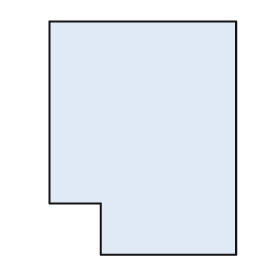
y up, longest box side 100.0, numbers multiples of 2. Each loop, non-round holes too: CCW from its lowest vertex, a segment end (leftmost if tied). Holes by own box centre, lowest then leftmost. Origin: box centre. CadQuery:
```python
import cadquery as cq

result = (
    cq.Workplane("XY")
    .moveTo(-18.0, -50.0)
    .lineTo(40.0, -50.0)
    .lineTo(40.0, 50.0)
    .lineTo(-40.0, 50.0)
    .lineTo(-40.0, -28.0)
    .lineTo(-18.0, -28.0)
    .close()
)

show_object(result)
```